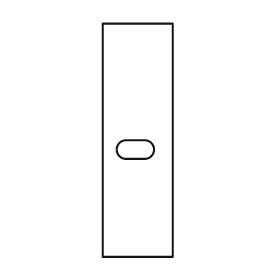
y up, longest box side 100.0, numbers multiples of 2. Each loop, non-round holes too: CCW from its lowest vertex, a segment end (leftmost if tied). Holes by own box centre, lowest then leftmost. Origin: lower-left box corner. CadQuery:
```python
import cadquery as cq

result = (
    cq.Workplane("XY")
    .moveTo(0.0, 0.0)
    .lineTo(30.0, 0.0)
    .lineTo(30.0, 100.0)
    .lineTo(0.0, 100.0)
    .close()
    .moveTo(10.0, 42.0)
    .lineTo(18.0, 42.0)
    .threePointArc((22.0, 46.0), (18.0, 50.0))
    .lineTo(10.0, 50.0)
    .threePointArc((6.0, 46.0), (10.0, 42.0))
    .close()
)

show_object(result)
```